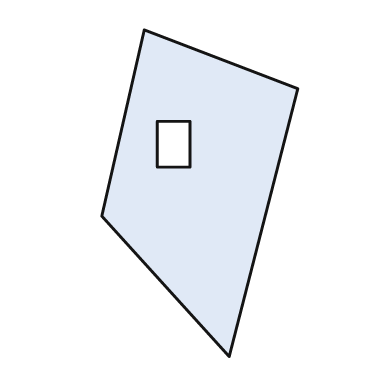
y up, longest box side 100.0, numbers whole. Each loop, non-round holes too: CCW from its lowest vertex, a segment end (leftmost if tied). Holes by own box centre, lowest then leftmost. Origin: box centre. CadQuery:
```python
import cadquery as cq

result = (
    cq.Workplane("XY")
    .moveTo(9.0, -50.0)
    .lineTo(30.0, 32.0)
    .lineTo(-17.0, 50.0)
    .lineTo(-30.0, -7.0)
    .close()
    .moveTo(-13.0, 8.0)
    .lineTo(-3.0, 8.0)
    .lineTo(-3.0, 22.0)
    .lineTo(-13.0, 22.0)
    .close()
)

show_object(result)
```